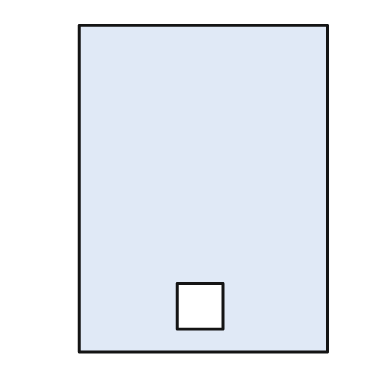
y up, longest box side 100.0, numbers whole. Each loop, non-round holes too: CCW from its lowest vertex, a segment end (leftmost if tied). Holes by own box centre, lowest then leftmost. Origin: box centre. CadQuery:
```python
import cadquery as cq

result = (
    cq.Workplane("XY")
    .moveTo(-38.0, -50.0)
    .lineTo(38.0, -50.0)
    .lineTo(38.0, 50.0)
    .lineTo(-38.0, 50.0)
    .close()
    .moveTo(-8.0, -43.0)
    .lineTo(6.0, -43.0)
    .lineTo(6.0, -29.0)
    .lineTo(-8.0, -29.0)
    .close()
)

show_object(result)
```